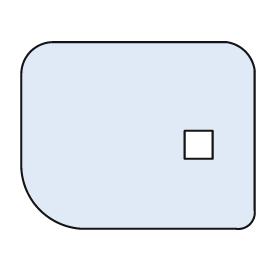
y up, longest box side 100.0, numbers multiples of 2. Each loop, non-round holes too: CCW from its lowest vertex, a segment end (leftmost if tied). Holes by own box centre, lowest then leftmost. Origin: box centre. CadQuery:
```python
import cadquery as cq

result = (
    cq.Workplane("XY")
    .moveTo(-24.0, -40.0)
    .lineTo(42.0, -40.0)
    .threePointArc((48.0, -38.0), (50.0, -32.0))
    .lineTo(50.0, 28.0)
    .threePointArc((46.0, 36.0), (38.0, 40.0))
    .lineTo(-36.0, 40.0)
    .threePointArc((-46.0, 36.0), (-50.0, 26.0))
    .lineTo(-50.0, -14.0)
    .threePointArc((-42.0, -32.0), (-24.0, -40.0))
    .close()
    .moveTo(20.0, -10.0)
    .lineTo(32.0, -10.0)
    .lineTo(32.0, 2.0)
    .lineTo(20.0, 2.0)
    .close()
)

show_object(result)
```